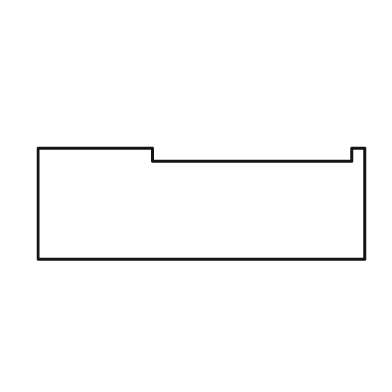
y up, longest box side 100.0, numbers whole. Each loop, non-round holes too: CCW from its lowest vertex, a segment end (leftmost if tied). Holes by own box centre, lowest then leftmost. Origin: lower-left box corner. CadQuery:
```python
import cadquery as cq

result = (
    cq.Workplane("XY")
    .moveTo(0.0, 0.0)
    .lineTo(100.0, 0.0)
    .lineTo(100.0, 34.0)
    .lineTo(96.0, 34.0)
    .lineTo(96.0, 30.0)
    .lineTo(35.0, 30.0)
    .lineTo(35.0, 34.0)
    .lineTo(0.0, 34.0)
    .close()
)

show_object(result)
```